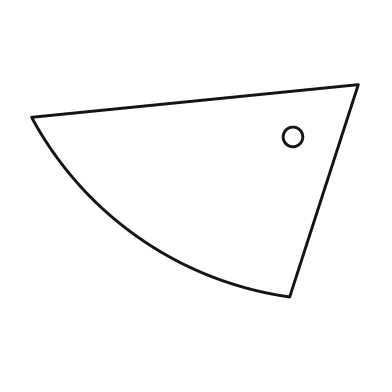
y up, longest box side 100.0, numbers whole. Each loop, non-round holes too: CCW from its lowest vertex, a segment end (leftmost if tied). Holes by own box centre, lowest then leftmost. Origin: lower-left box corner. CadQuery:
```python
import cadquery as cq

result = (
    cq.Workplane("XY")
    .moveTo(79.0, 0.0)
    .lineTo(100.0, 65.0)
    .lineTo(0.0, 55.0)
    .threePointArc((33.0, 18.0), (79.0, 0.0))
    .close()
    .moveTo(80.0, 49.0)
    .circle(3.0)
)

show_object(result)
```